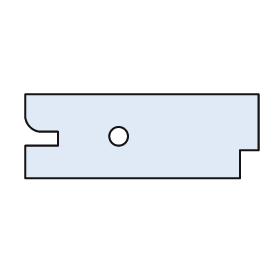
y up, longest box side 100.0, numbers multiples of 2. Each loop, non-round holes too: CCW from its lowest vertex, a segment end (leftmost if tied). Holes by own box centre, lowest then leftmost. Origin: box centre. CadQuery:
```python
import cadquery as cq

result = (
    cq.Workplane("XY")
    .moveTo(-50.0, -18.0)
    .lineTo(42.0, -18.0)
    .lineTo(42.0, -6.0)
    .lineTo(50.0, -6.0)
    .lineTo(50.0, 18.0)
    .lineTo(-50.0, 18.0)
    .lineTo(-50.0, 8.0)
    .threePointArc((-48.0, 4.0), (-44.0, 2.0))
    .lineTo(-36.0, 2.0)
    .lineTo(-36.0, -4.0)
    .lineTo(-50.0, -4.0)
    .close()
    .moveTo(-10.0, 0.0)
    .circle(4.0)
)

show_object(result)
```